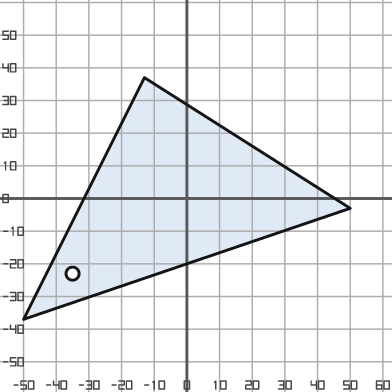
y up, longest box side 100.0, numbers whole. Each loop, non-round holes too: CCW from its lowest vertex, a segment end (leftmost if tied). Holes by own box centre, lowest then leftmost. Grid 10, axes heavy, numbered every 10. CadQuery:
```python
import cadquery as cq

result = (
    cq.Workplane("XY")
    .moveTo(-50.0, -37.0)
    .lineTo(50.0, -3.0)
    .lineTo(-13.0, 37.0)
    .close()
    .moveTo(-35.0, -23.0)
    .circle(2.0)
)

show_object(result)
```